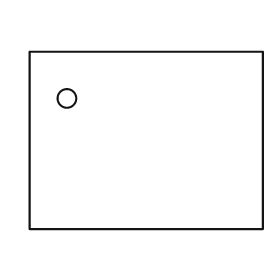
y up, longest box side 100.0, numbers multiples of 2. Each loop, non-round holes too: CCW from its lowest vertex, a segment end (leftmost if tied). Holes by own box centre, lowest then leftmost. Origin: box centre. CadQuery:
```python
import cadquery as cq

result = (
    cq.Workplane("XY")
    .moveTo(-50.0, -38.0)
    .lineTo(50.0, -38.0)
    .lineTo(50.0, 38.0)
    .lineTo(-50.0, 38.0)
    .close()
    .moveTo(-34.0, 18.0)
    .circle(4.0)
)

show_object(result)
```